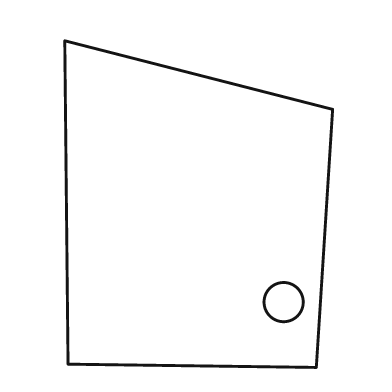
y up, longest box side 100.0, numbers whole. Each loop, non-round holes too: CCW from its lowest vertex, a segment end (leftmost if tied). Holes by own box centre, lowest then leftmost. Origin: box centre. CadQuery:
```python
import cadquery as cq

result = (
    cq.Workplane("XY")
    .moveTo(36.0, -50.0)
    .lineTo(41.0, 29.0)
    .lineTo(-41.0, 50.0)
    .lineTo(-40.0, -49.0)
    .close()
    .moveTo(26.0, -30.0)
    .circle(6.0)
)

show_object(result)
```